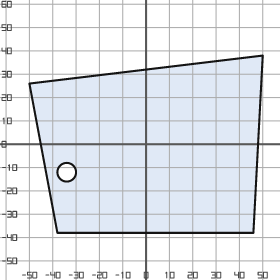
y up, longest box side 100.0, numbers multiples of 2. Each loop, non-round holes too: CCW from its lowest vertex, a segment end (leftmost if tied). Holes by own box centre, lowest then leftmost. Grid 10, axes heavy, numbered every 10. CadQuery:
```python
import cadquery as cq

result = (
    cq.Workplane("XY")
    .moveTo(-38.0, -38.0)
    .lineTo(46.0, -38.0)
    .lineTo(50.0, 38.0)
    .lineTo(-50.0, 26.0)
    .close()
    .moveTo(-34.0, -12.0)
    .circle(4.0)
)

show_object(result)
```